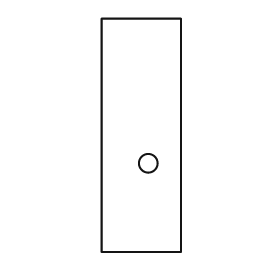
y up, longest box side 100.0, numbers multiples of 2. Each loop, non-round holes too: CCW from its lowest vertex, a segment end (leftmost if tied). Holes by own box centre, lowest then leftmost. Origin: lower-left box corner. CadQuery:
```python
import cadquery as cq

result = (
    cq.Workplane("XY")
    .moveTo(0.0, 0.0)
    .lineTo(34.0, 0.0)
    .lineTo(34.0, 100.0)
    .lineTo(0.0, 100.0)
    .close()
    .moveTo(20.0, 38.0)
    .circle(4.0)
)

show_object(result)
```